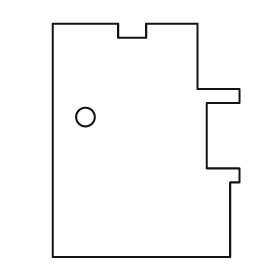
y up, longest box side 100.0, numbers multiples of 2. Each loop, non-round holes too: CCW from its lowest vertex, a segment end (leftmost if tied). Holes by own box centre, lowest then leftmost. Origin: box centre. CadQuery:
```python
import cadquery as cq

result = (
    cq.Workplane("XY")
    .moveTo(-40.0, -50.0)
    .lineTo(36.0, -50.0)
    .lineTo(36.0, -18.0)
    .lineTo(40.0, -18.0)
    .lineTo(40.0, -12.0)
    .lineTo(26.0, -12.0)
    .lineTo(26.0, 16.0)
    .lineTo(40.0, 16.0)
    .lineTo(40.0, 22.0)
    .lineTo(22.0, 22.0)
    .lineTo(22.0, 50.0)
    .lineTo(0.0, 50.0)
    .lineTo(0.0, 44.0)
    .lineTo(-12.0, 44.0)
    .lineTo(-12.0, 50.0)
    .lineTo(-40.0, 50.0)
    .close()
    .moveTo(-26.0, 10.0)
    .circle(4.0)
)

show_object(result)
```